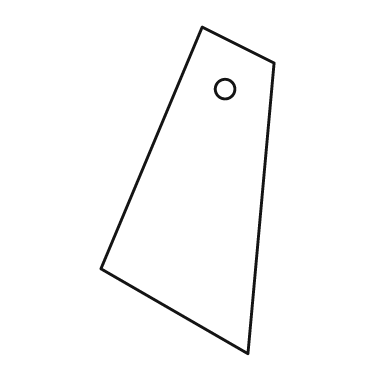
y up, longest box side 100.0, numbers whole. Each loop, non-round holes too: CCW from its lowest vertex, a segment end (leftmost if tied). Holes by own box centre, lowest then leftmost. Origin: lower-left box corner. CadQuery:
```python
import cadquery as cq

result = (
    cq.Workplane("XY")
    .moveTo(45.0, 0.0)
    .lineTo(53.0, 89.0)
    .lineTo(31.0, 100.0)
    .lineTo(0.0, 26.0)
    .close()
    .moveTo(38.0, 81.0)
    .circle(3.0)
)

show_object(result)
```